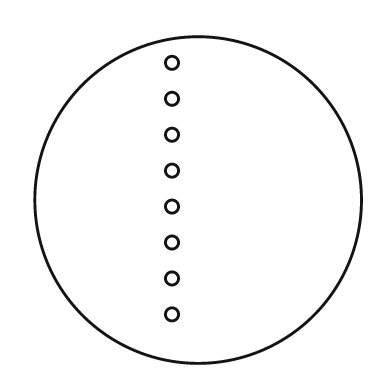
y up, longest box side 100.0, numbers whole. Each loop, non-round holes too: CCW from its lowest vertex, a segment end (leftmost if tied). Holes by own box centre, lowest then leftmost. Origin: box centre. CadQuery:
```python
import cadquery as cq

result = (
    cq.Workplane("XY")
    .moveTo(0.0, 0.0)
    .circle(50.0)
    .moveTo(-8.0, -35.0)
    .circle(2.0)
    .moveTo(-8.0, -24.0)
    .circle(2.0)
    .moveTo(-8.0, -13.0)
    .circle(2.0)
    .moveTo(-8.0, -2.0)
    .circle(2.0)
    .moveTo(-8.0, 9.0)
    .circle(2.0)
    .moveTo(-8.0, 20.0)
    .circle(2.0)
    .moveTo(-8.0, 31.0)
    .circle(2.0)
    .moveTo(-8.0, 42.0)
    .circle(2.0)
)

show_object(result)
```